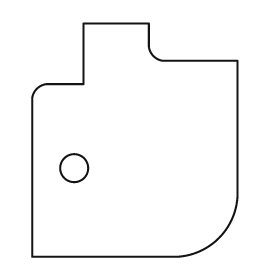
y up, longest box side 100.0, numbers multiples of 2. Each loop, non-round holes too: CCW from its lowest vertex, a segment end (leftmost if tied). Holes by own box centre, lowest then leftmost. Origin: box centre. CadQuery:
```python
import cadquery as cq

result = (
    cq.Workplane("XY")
    .moveTo(-44.0, -50.0)
    .lineTo(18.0, -50.0)
    .threePointArc((36.0, -42.0), (44.0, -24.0))
    .lineTo(44.0, 34.0)
    .lineTo(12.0, 34.0)
    .threePointArc((8.0, 36.0), (6.0, 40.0))
    .lineTo(6.0, 50.0)
    .lineTo(-22.0, 50.0)
    .lineTo(-22.0, 24.0)
    .lineTo(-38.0, 24.0)
    .threePointArc((-42.0, 22.0), (-44.0, 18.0))
    .close()
    .moveTo(-26.0, -12.0)
    .circle(6.0)
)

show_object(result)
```